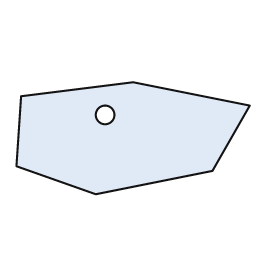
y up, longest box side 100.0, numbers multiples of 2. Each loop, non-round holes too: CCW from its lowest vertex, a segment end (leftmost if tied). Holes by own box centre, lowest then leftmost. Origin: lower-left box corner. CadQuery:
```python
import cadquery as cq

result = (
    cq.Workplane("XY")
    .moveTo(34.0, 0.0)
    .lineTo(84.0, 10.0)
    .lineTo(100.0, 38.0)
    .lineTo(50.0, 48.0)
    .lineTo(2.0, 42.0)
    .lineTo(0.0, 12.0)
    .close()
    .moveTo(38.0, 34.0)
    .circle(4.0)
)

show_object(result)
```